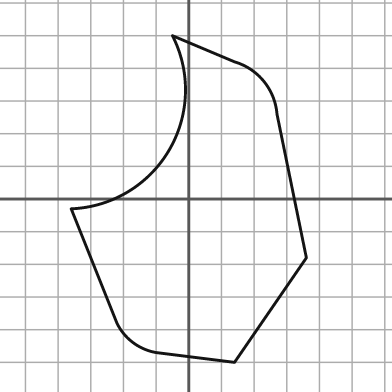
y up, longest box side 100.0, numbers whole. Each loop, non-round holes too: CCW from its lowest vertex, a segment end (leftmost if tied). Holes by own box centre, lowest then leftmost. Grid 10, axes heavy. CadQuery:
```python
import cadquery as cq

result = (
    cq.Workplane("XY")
    .moveTo(14.0, -50.0)
    .lineTo(36.0, -18.0)
    .lineTo(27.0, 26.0)
    .threePointArc((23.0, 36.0), (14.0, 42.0))
    .lineTo(-5.0, 50.0)
    .threePointArc((-6.0, 15.0), (-36.0, -3.0))
    .lineTo(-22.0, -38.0)
    .threePointArc((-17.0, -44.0), (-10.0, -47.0))
    .close()
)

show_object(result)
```